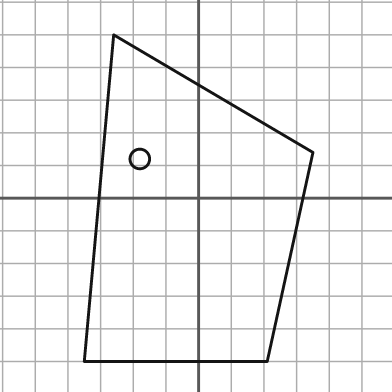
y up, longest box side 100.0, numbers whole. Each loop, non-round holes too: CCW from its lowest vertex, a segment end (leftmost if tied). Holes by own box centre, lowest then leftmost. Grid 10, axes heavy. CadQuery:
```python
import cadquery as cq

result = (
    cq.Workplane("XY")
    .moveTo(-35.0, -50.0)
    .lineTo(21.0, -50.0)
    .lineTo(35.0, 14.0)
    .lineTo(-26.0, 50.0)
    .close()
    .moveTo(-18.0, 12.0)
    .circle(3.0)
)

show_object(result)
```